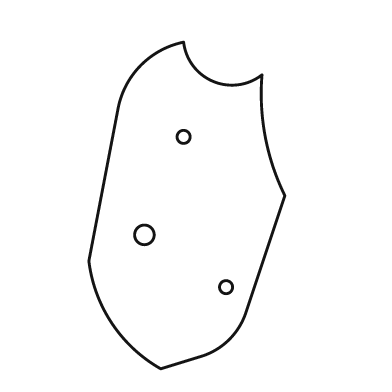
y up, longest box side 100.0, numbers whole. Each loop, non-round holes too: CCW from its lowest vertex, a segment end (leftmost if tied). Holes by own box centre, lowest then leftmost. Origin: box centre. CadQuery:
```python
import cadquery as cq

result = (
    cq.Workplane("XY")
    .moveTo(-8.0, -50.0)
    .lineTo(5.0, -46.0)
    .threePointArc((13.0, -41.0), (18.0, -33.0))
    .lineTo(30.0, 3.0)
    .threePointArc((24.0, 21.0), (23.0, 40.0))
    .threePointArc((8.0, 38.0), (-1.0, 50.0))
    .threePointArc((-14.0, 43.0), (-21.0, 30.0))
    .lineTo(-30.0, -17.0)
    .threePointArc((-23.0, -36.0), (-8.0, -50.0))
    .close()
    .moveTo(12.0, -25.0)
    .circle(2.0)
    .moveTo(-13.0, -9.0)
    .circle(3.0)
    .moveTo(-1.0, 21.0)
    .circle(2.0)
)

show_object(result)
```